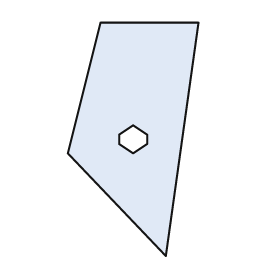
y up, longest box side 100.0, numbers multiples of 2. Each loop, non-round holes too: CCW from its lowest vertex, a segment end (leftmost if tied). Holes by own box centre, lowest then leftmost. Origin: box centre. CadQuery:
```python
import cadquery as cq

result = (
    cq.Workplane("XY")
    .moveTo(14.0, -50.0)
    .lineTo(28.0, 50.0)
    .lineTo(-14.0, 50.0)
    .lineTo(-28.0, -6.0)
    .close()
    .moveTo(0.0, -6.0)
    .lineTo(6.0, -2.0)
    .lineTo(6.0, 2.0)
    .lineTo(0.0, 6.0)
    .lineTo(-6.0, 2.0)
    .lineTo(-6.0, -2.0)
    .close()
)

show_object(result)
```